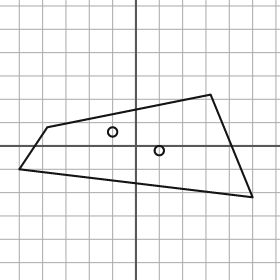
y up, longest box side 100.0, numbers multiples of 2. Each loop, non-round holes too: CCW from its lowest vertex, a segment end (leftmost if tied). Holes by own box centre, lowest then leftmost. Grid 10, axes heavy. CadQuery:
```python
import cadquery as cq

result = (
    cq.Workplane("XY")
    .moveTo(50.0, -22.0)
    .lineTo(32.0, 22.0)
    .lineTo(-38.0, 8.0)
    .lineTo(-50.0, -10.0)
    .close()
    .moveTo(10.0, -2.0)
    .circle(2.0)
    .moveTo(-10.0, 6.0)
    .circle(2.0)
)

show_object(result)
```